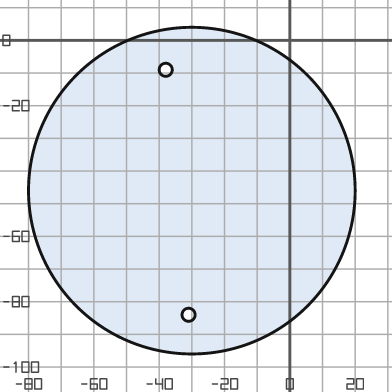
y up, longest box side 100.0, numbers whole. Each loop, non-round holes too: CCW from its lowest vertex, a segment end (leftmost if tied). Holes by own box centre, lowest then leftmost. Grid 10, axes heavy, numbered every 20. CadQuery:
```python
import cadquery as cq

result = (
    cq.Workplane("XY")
    .moveTo(-30.0, -46.0)
    .circle(50.0)
    .moveTo(-31.0, -84.0)
    .circle(2.0)
    .moveTo(-38.0, -9.0)
    .circle(2.0)
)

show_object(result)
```